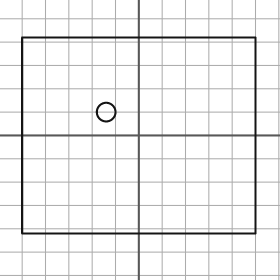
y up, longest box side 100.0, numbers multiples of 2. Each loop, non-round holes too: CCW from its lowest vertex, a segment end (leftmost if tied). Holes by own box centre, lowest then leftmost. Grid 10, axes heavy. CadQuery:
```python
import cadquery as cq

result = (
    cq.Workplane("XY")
    .moveTo(-50.0, -42.0)
    .lineTo(50.0, -42.0)
    .lineTo(50.0, 42.0)
    .lineTo(-50.0, 42.0)
    .close()
    .moveTo(-14.0, 10.0)
    .circle(4.0)
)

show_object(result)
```